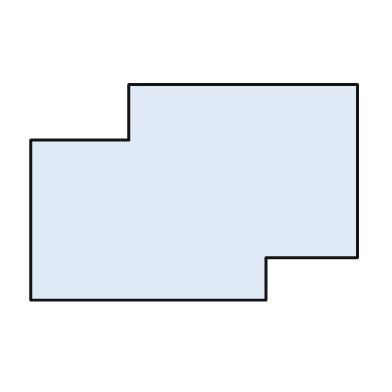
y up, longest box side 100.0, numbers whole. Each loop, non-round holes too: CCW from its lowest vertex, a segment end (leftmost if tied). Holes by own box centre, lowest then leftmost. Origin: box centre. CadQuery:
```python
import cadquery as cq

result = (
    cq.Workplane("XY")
    .moveTo(-50.0, -33.0)
    .lineTo(22.0, -33.0)
    .lineTo(22.0, -20.0)
    .lineTo(50.0, -20.0)
    .lineTo(50.0, 33.0)
    .lineTo(-20.0, 33.0)
    .lineTo(-20.0, 16.0)
    .lineTo(-50.0, 16.0)
    .close()
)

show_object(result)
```